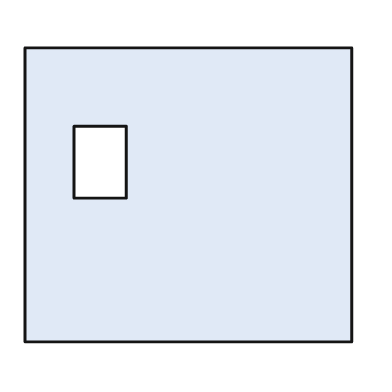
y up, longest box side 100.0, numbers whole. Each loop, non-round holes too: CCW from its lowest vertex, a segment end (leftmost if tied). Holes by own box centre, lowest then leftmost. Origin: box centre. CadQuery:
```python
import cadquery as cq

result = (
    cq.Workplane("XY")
    .moveTo(-50.0, -45.0)
    .lineTo(50.0, -45.0)
    .lineTo(50.0, 45.0)
    .lineTo(-50.0, 45.0)
    .close()
    .moveTo(-35.0, -1.0)
    .lineTo(-19.0, -1.0)
    .lineTo(-19.0, 21.0)
    .lineTo(-35.0, 21.0)
    .close()
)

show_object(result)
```